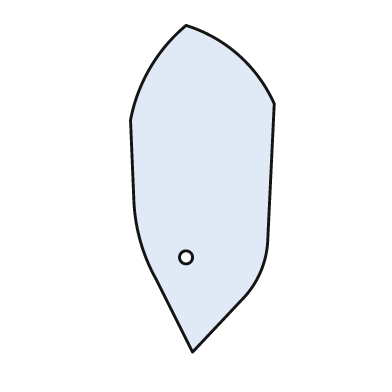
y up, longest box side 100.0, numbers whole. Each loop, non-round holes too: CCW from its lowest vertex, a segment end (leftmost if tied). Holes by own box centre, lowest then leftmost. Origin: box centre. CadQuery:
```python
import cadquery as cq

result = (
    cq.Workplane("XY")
    .moveTo(-3.0, -50.0)
    .lineTo(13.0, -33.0)
    .threePointArc((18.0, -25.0), (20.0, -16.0))
    .lineTo(22.0, 26.0)
    .threePointArc((11.0, 41.0), (-5.0, 50.0))
    .threePointArc((-16.0, 37.0), (-22.0, 21.0))
    .lineTo(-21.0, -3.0)
    .threePointArc((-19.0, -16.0), (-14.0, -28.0))
    .close()
    .moveTo(-5.0, -21.0)
    .circle(2.0)
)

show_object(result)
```